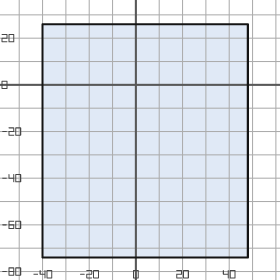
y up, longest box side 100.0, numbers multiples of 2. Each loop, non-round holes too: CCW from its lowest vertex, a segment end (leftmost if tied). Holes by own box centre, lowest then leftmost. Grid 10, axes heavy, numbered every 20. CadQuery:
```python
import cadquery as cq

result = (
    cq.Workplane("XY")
    .moveTo(-40.0, -74.0)
    .lineTo(48.0, -74.0)
    .lineTo(48.0, 26.0)
    .lineTo(-40.0, 26.0)
    .close()
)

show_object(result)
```